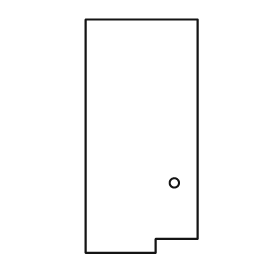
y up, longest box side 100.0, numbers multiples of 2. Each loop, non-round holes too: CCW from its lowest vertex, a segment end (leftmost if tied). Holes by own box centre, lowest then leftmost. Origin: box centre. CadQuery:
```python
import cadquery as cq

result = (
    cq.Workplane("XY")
    .moveTo(-24.0, -50.0)
    .lineTo(6.0, -50.0)
    .lineTo(6.0, -44.0)
    .lineTo(24.0, -44.0)
    .lineTo(24.0, 50.0)
    .lineTo(-24.0, 50.0)
    .close()
    .moveTo(14.0, -20.0)
    .circle(2.0)
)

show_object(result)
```